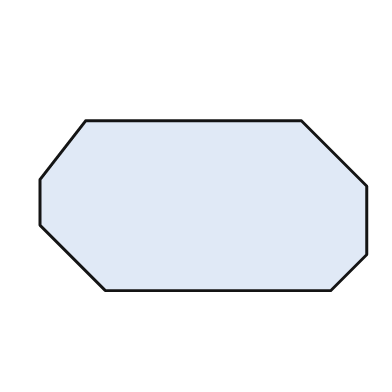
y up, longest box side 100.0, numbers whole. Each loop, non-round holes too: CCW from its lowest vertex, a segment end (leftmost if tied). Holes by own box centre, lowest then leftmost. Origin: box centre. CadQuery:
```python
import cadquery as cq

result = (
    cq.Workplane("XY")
    .moveTo(-30.0, -26.0)
    .lineTo(39.0, -26.0)
    .lineTo(50.0, -15.0)
    .lineTo(50.0, 6.0)
    .lineTo(30.0, 26.0)
    .lineTo(-36.0, 26.0)
    .lineTo(-50.0, 8.0)
    .lineTo(-50.0, -6.0)
    .close()
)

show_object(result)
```